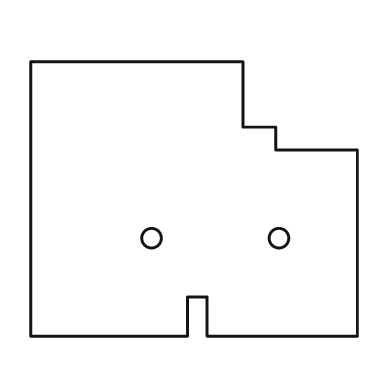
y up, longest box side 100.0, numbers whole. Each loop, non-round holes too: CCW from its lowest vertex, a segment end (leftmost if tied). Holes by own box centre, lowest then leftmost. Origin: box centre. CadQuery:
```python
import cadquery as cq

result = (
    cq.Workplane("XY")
    .moveTo(-50.0, -42.0)
    .lineTo(-2.0, -42.0)
    .lineTo(-2.0, -30.0)
    .lineTo(4.0, -30.0)
    .lineTo(4.0, -42.0)
    .lineTo(50.0, -42.0)
    .lineTo(50.0, 15.0)
    .lineTo(25.0, 15.0)
    .lineTo(25.0, 22.0)
    .lineTo(15.0, 22.0)
    .lineTo(15.0, 42.0)
    .lineTo(-50.0, 42.0)
    .close()
    .moveTo(-13.0, -12.0)
    .circle(3.0)
    .moveTo(26.0, -12.0)
    .circle(3.0)
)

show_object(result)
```